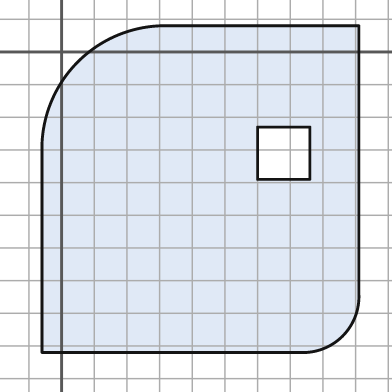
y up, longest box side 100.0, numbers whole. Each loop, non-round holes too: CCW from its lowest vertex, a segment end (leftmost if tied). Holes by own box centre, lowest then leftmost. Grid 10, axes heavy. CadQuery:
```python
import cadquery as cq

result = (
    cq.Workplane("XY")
    .moveTo(-6.0, -92.0)
    .lineTo(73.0, -92.0)
    .threePointArc((86.0, -87.0), (91.0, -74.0))
    .lineTo(91.0, 8.0)
    .lineTo(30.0, 8.0)
    .threePointArc((5.0, -3.0), (-6.0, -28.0))
    .close()
    .moveTo(60.0, -39.0)
    .lineTo(76.0, -39.0)
    .lineTo(76.0, -23.0)
    .lineTo(60.0, -23.0)
    .close()
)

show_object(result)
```